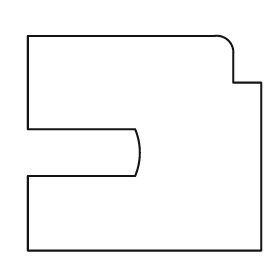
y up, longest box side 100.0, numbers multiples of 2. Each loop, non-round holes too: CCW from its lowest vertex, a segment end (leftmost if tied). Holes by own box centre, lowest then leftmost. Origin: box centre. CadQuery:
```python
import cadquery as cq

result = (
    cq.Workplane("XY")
    .moveTo(-50.0, -46.0)
    .lineTo(50.0, -46.0)
    .lineTo(50.0, 26.0)
    .lineTo(38.0, 26.0)
    .lineTo(38.0, 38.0)
    .threePointArc((36.0, 44.0), (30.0, 46.0))
    .lineTo(-50.0, 46.0)
    .lineTo(-50.0, 6.0)
    .lineTo(-4.0, 6.0)
    .threePointArc((-2.0, -4.0), (-4.0, -14.0))
    .lineTo(-50.0, -14.0)
    .close()
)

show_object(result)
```